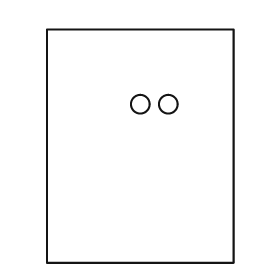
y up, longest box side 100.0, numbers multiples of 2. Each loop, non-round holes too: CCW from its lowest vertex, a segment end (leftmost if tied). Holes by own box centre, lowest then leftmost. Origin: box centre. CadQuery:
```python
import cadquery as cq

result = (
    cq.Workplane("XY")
    .moveTo(-40.0, -50.0)
    .lineTo(40.0, -50.0)
    .lineTo(40.0, 50.0)
    .lineTo(-40.0, 50.0)
    .close()
    .moveTo(0.0, 18.0)
    .circle(4.0)
    .moveTo(12.0, 18.0)
    .circle(4.0)
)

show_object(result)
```